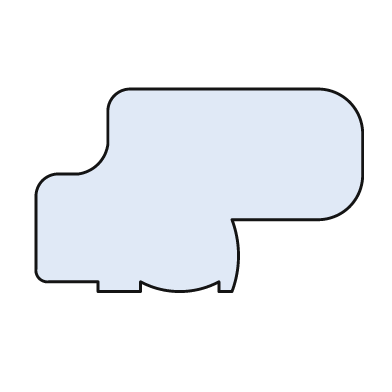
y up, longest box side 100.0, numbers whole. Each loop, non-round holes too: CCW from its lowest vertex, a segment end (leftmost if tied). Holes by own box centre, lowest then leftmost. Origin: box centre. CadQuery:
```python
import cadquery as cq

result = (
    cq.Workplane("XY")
    .moveTo(-31.0, -31.0)
    .lineTo(-18.0, -31.0)
    .lineTo(-18.0, -28.0)
    .threePointArc((-6.0, -31.0), (6.0, -28.0))
    .lineTo(6.0, -31.0)
    .lineTo(10.0, -31.0)
    .threePointArc((12.0, -20.0), (10.0, -9.0))
    .lineTo(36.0, -9.0)
    .threePointArc((46.0, -5.0), (50.0, 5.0))
    .lineTo(50.0, 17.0)
    .threePointArc((46.0, 27.0), (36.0, 31.0))
    .lineTo(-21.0, 31.0)
    .threePointArc((-26.0, 29.0), (-28.0, 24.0))
    .lineTo(-28.0, 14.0)
    .threePointArc((-31.0, 8.0), (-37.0, 5.0))
    .lineTo(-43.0, 5.0)
    .threePointArc((-48.0, 3.0), (-50.0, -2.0))
    .lineTo(-50.0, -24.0)
    .threePointArc((-49.0, -27.0), (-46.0, -28.0))
    .lineTo(-31.0, -28.0)
    .close()
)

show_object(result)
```